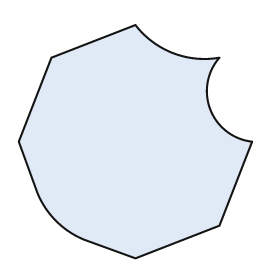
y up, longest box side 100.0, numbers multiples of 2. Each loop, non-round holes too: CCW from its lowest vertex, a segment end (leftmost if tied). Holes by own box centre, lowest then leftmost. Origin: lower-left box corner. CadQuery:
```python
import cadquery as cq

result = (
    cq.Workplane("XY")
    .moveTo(50.0, 0.0)
    .lineTo(86.0, 14.0)
    .lineTo(100.0, 50.0)
    .threePointArc((82.0, 64.0), (86.0, 86.0))
    .threePointArc((66.0, 88.0), (50.0, 100.0))
    .lineTo(14.0, 86.0)
    .lineTo(0.0, 50.0)
    .lineTo(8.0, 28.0)
    .threePointArc((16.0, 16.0), (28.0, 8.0))
    .close()
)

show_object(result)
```